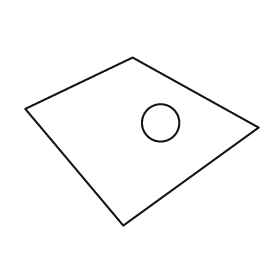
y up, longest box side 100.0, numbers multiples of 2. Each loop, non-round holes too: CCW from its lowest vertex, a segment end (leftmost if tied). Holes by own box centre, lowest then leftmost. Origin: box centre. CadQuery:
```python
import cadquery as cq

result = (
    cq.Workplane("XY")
    .moveTo(-8.0, -36.0)
    .lineTo(50.0, 6.0)
    .lineTo(-4.0, 36.0)
    .lineTo(-50.0, 14.0)
    .close()
    .moveTo(8.0, 8.0)
    .circle(8.0)
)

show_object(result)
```